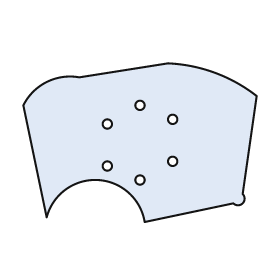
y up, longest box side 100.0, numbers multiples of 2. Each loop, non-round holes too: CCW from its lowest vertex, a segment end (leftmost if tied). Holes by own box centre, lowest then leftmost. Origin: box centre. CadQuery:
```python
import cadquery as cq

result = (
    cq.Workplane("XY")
    .moveTo(2.0, -34.0)
    .lineTo(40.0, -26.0)
    .threePointArc((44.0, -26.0), (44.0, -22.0))
    .lineTo(50.0, 20.0)
    .threePointArc((32.0, 30.0), (12.0, 34.0))
    .lineTo(-26.0, 28.0)
    .threePointArc((-40.0, 26.0), (-50.0, 16.0))
    .lineTo(-40.0, -32.0)
    .threePointArc((-18.0, -16.0), (2.0, -34.0))
    .close()
    .moveTo(0.0, -16.0)
    .circle(2.0)
    .moveTo(-14.0, -10.0)
    .circle(2.0)
    .moveTo(14.0, -8.0)
    .circle(2.0)
    .moveTo(-14.0, 8.0)
    .circle(2.0)
    .moveTo(14.0, 10.0)
    .circle(2.0)
    .moveTo(0.0, 16.0)
    .circle(2.0)
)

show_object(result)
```